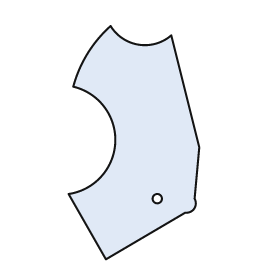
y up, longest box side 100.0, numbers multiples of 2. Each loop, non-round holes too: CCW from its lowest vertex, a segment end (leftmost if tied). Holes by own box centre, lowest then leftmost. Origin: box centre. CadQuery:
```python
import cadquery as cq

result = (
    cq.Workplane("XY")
    .moveTo(-12.0, -50.0)
    .lineTo(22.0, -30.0)
    .threePointArc((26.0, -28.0), (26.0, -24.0))
    .lineTo(28.0, -2.0)
    .lineTo(16.0, 46.0)
    .threePointArc((2.0, 42.0), (-10.0, 50.0))
    .threePointArc((-20.0, 38.0), (-26.0, 24.0))
    .threePointArc((-8.0, 0.0), (-28.0, -22.0))
    .close()
    .moveTo(10.0, -24.0)
    .circle(2.0)
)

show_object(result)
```